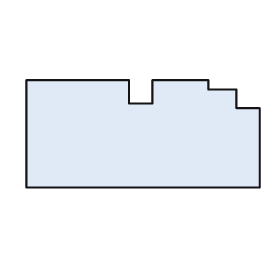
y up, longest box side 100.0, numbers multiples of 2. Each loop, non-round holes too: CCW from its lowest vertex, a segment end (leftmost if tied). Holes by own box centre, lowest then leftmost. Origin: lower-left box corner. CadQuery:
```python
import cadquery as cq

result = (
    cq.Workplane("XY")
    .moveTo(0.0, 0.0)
    .lineTo(100.0, 0.0)
    .lineTo(100.0, 34.0)
    .lineTo(90.0, 34.0)
    .lineTo(90.0, 42.0)
    .lineTo(78.0, 42.0)
    .lineTo(78.0, 46.0)
    .lineTo(54.0, 46.0)
    .lineTo(54.0, 36.0)
    .lineTo(44.0, 36.0)
    .lineTo(44.0, 46.0)
    .lineTo(0.0, 46.0)
    .close()
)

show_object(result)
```